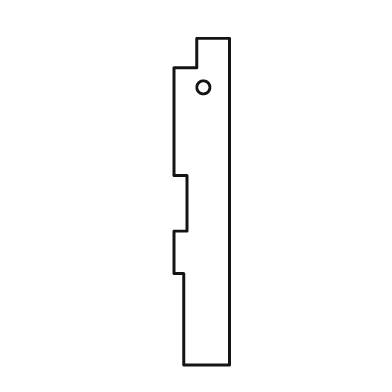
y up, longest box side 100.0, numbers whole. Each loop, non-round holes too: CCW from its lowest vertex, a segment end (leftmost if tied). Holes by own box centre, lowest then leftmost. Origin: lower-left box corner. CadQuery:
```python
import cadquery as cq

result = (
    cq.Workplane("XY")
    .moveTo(3.0, 0.0)
    .lineTo(17.0, 0.0)
    .lineTo(17.0, 100.0)
    .lineTo(7.0, 100.0)
    .lineTo(7.0, 91.0)
    .lineTo(0.0, 91.0)
    .lineTo(0.0, 58.0)
    .lineTo(4.0, 58.0)
    .lineTo(4.0, 41.0)
    .lineTo(0.0, 41.0)
    .lineTo(0.0, 28.0)
    .lineTo(3.0, 28.0)
    .close()
    .moveTo(9.0, 85.0)
    .circle(2.0)
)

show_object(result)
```